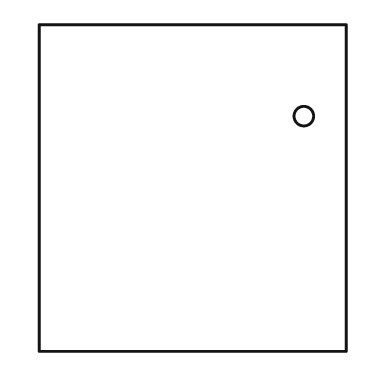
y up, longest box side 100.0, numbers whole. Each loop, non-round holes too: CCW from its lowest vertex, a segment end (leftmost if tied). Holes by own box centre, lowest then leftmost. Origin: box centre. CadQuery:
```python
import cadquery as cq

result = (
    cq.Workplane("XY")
    .moveTo(-47.0, -50.0)
    .lineTo(47.0, -50.0)
    .lineTo(47.0, 50.0)
    .lineTo(-47.0, 50.0)
    .close()
    .moveTo(34.0, 22.0)
    .circle(3.0)
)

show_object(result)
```